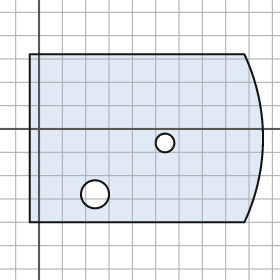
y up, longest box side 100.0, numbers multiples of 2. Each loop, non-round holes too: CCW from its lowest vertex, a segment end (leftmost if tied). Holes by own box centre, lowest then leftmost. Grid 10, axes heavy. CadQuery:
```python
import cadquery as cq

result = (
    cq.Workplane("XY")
    .moveTo(-4.0, -40.0)
    .lineTo(88.0, -40.0)
    .threePointArc((96.0, -4.0), (88.0, 32.0))
    .lineTo(-4.0, 32.0)
    .close()
    .moveTo(24.0, -28.0)
    .circle(6.0)
    .moveTo(54.0, -6.0)
    .circle(4.0)
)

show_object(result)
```